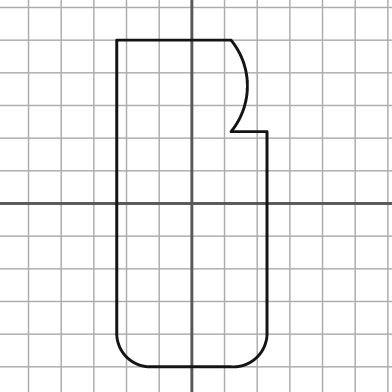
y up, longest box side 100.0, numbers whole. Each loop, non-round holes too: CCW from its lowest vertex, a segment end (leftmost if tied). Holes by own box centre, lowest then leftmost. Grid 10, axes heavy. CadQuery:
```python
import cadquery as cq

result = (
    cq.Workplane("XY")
    .moveTo(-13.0, -50.0)
    .lineTo(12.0, -50.0)
    .threePointArc((20.0, -47.0), (23.0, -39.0))
    .lineTo(23.0, 22.0)
    .lineTo(12.0, 22.0)
    .threePointArc((17.0, 36.0), (12.0, 50.0))
    .lineTo(-23.0, 50.0)
    .lineTo(-23.0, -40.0)
    .threePointArc((-20.0, -47.0), (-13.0, -50.0))
    .close()
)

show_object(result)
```